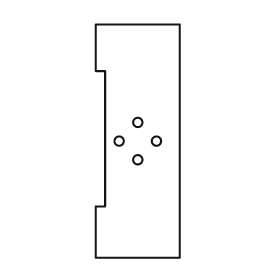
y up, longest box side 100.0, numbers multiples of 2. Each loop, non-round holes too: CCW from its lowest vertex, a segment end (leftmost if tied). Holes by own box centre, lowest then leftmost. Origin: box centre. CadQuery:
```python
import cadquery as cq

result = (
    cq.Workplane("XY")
    .moveTo(-18.0, -50.0)
    .lineTo(18.0, -50.0)
    .lineTo(18.0, 50.0)
    .lineTo(-18.0, 50.0)
    .lineTo(-18.0, 30.0)
    .lineTo(-14.0, 30.0)
    .lineTo(-14.0, -28.0)
    .lineTo(-18.0, -28.0)
    .close()
    .moveTo(0.0, -8.0)
    .circle(2.0)
    .moveTo(-8.0, 0.0)
    .circle(2.0)
    .moveTo(8.0, 0.0)
    .circle(2.0)
    .moveTo(0.0, 8.0)
    .circle(2.0)
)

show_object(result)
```